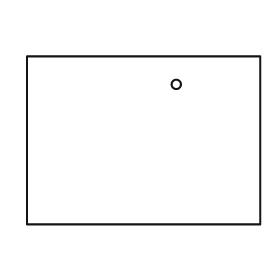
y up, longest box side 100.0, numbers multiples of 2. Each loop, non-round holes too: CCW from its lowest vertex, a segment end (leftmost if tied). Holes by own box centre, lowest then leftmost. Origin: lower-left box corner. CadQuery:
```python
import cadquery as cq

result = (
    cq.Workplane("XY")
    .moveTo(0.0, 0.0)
    .lineTo(100.0, 0.0)
    .lineTo(100.0, 72.0)
    .lineTo(0.0, 72.0)
    .close()
    .moveTo(64.0, 60.0)
    .circle(2.0)
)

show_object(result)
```